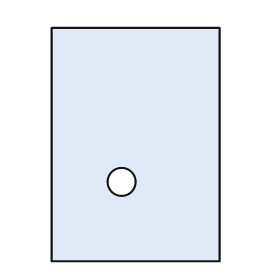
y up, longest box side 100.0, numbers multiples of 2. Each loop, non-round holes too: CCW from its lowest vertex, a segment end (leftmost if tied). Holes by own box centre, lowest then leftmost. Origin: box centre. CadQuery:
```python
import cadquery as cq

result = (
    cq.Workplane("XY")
    .moveTo(-36.0, -50.0)
    .lineTo(36.0, -50.0)
    .lineTo(36.0, 50.0)
    .lineTo(-36.0, 50.0)
    .close()
    .moveTo(-6.0, -16.0)
    .circle(6.0)
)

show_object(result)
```